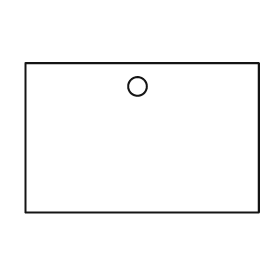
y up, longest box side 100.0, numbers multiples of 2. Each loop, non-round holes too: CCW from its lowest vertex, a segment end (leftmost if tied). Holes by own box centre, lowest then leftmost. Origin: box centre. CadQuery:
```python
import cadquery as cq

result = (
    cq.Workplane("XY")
    .moveTo(-50.0, -32.0)
    .lineTo(50.0, -32.0)
    .lineTo(50.0, 32.0)
    .lineTo(-50.0, 32.0)
    .close()
    .moveTo(-2.0, 22.0)
    .circle(4.0)
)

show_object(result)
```